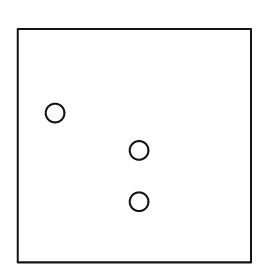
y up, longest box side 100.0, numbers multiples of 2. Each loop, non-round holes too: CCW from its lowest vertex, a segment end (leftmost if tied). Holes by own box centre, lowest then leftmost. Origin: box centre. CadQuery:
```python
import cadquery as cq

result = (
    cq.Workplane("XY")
    .moveTo(-50.0, -50.0)
    .lineTo(50.0, -50.0)
    .lineTo(50.0, 50.0)
    .lineTo(-50.0, 50.0)
    .close()
    .moveTo(2.0, -24.0)
    .circle(4.0)
    .moveTo(2.0, -2.0)
    .circle(4.0)
    .moveTo(-34.0, 14.0)
    .circle(4.0)
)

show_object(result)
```